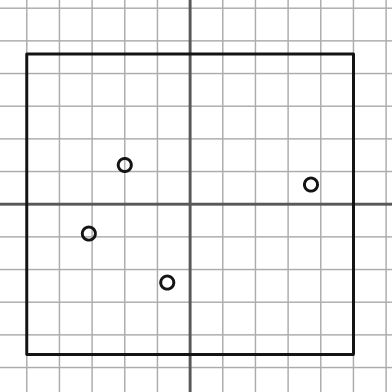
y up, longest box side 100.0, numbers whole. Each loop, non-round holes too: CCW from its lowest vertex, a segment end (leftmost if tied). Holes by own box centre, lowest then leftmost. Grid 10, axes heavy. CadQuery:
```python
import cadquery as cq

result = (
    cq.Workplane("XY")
    .moveTo(-50.0, -46.0)
    .lineTo(50.0, -46.0)
    .lineTo(50.0, 46.0)
    .lineTo(-50.0, 46.0)
    .close()
    .moveTo(-7.0, -24.0)
    .circle(2.0)
    .moveTo(-31.0, -9.0)
    .circle(2.0)
    .moveTo(37.0, 6.0)
    .circle(2.0)
    .moveTo(-20.0, 12.0)
    .circle(2.0)
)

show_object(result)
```